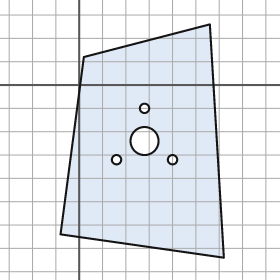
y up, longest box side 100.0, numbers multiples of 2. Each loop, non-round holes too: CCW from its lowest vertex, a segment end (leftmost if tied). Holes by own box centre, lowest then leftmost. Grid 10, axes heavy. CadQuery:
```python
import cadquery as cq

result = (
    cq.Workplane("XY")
    .moveTo(62.0, -74.0)
    .lineTo(56.0, 26.0)
    .lineTo(2.0, 12.0)
    .lineTo(-8.0, -64.0)
    .close()
    .moveTo(16.0, -32.0)
    .circle(2.0)
    .moveTo(40.0, -32.0)
    .circle(2.0)
    .moveTo(28.0, -24.0)
    .circle(6.0)
    .moveTo(28.0, -10.0)
    .circle(2.0)
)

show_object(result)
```